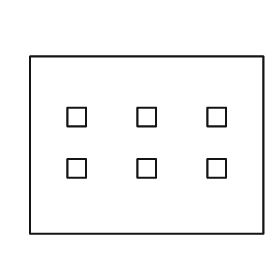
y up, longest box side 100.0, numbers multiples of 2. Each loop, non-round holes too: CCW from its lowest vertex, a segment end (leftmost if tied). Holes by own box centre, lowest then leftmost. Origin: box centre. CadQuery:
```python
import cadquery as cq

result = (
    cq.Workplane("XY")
    .moveTo(-50.0, -38.0)
    .lineTo(50.0, -38.0)
    .lineTo(50.0, 38.0)
    .lineTo(-50.0, 38.0)
    .close()
    .moveTo(-34.0, -14.0)
    .lineTo(-26.0, -14.0)
    .lineTo(-26.0, -6.0)
    .lineTo(-34.0, -6.0)
    .close()
    .moveTo(-4.0, -14.0)
    .lineTo(4.0, -14.0)
    .lineTo(4.0, -6.0)
    .lineTo(-4.0, -6.0)
    .close()
    .moveTo(26.0, -14.0)
    .lineTo(34.0, -14.0)
    .lineTo(34.0, -6.0)
    .lineTo(26.0, -6.0)
    .close()
    .moveTo(-34.0, 8.0)
    .lineTo(-26.0, 8.0)
    .lineTo(-26.0, 16.0)
    .lineTo(-34.0, 16.0)
    .close()
    .moveTo(-4.0, 8.0)
    .lineTo(4.0, 8.0)
    .lineTo(4.0, 16.0)
    .lineTo(-4.0, 16.0)
    .close()
    .moveTo(26.0, 8.0)
    .lineTo(34.0, 8.0)
    .lineTo(34.0, 16.0)
    .lineTo(26.0, 16.0)
    .close()
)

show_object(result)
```